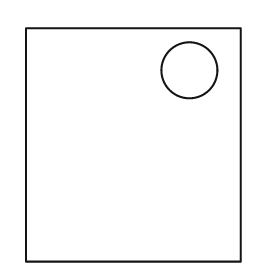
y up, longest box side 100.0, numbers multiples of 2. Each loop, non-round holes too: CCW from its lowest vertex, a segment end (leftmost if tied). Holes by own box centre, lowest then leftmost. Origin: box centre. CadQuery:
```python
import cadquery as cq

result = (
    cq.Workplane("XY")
    .moveTo(-46.0, -50.0)
    .lineTo(46.0, -50.0)
    .lineTo(46.0, 50.0)
    .lineTo(-46.0, 50.0)
    .close()
    .moveTo(24.0, 32.0)
    .circle(12.0)
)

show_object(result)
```